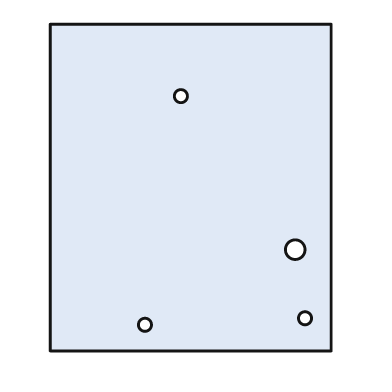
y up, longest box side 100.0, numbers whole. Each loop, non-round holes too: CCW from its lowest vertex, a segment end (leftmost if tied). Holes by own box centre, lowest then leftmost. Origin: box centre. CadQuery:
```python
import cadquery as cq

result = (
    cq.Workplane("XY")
    .moveTo(-43.0, -50.0)
    .lineTo(43.0, -50.0)
    .lineTo(43.0, 50.0)
    .lineTo(-43.0, 50.0)
    .close()
    .moveTo(-14.0, -42.0)
    .circle(2.0)
    .moveTo(35.0, -40.0)
    .circle(2.0)
    .moveTo(32.0, -19.0)
    .circle(3.0)
    .moveTo(-3.0, 28.0)
    .circle(2.0)
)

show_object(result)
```